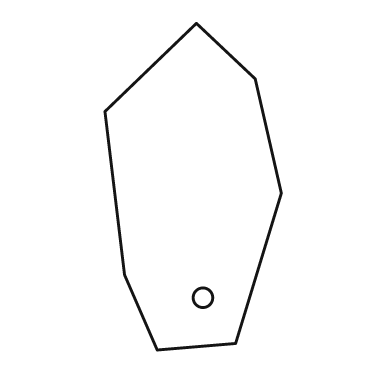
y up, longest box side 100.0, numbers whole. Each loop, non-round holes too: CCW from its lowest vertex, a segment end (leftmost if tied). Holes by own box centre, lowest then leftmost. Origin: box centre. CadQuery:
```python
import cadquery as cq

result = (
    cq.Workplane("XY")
    .moveTo(-11.0, -50.0)
    .lineTo(13.0, -48.0)
    .lineTo(27.0, -2.0)
    .lineTo(19.0, 33.0)
    .lineTo(1.0, 50.0)
    .lineTo(-27.0, 23.0)
    .lineTo(-21.0, -27.0)
    .close()
    .moveTo(3.0, -34.0)
    .circle(3.0)
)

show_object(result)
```